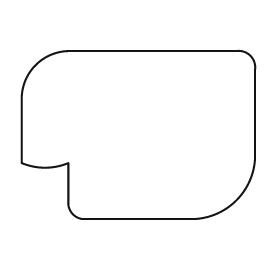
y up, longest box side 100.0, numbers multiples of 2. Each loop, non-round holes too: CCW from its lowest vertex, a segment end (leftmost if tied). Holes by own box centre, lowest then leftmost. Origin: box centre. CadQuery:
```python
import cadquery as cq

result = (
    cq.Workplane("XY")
    .moveTo(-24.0, -36.0)
    .lineTo(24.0, -36.0)
    .threePointArc((42.0, -28.0), (50.0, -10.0))
    .lineTo(50.0, 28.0)
    .threePointArc((48.0, 34.0), (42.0, 36.0))
    .lineTo(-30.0, 36.0)
    .threePointArc((-44.0, 30.0), (-50.0, 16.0))
    .lineTo(-50.0, -12.0)
    .threePointArc((-40.0, -14.0), (-30.0, -12.0))
    .lineTo(-30.0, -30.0)
    .threePointArc((-28.0, -34.0), (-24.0, -36.0))
    .close()
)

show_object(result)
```